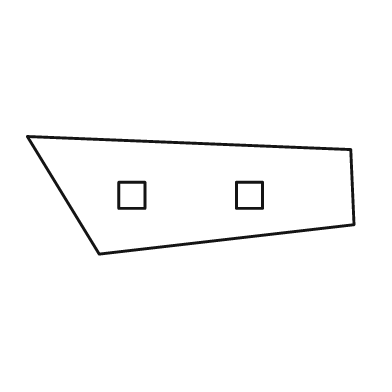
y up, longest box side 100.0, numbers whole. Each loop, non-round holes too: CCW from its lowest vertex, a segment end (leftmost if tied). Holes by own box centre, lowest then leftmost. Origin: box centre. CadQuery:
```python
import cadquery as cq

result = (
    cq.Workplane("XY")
    .moveTo(-28.0, -18.0)
    .lineTo(50.0, -9.0)
    .lineTo(49.0, 14.0)
    .lineTo(-50.0, 18.0)
    .close()
    .moveTo(-22.0, -4.0)
    .lineTo(-14.0, -4.0)
    .lineTo(-14.0, 4.0)
    .lineTo(-22.0, 4.0)
    .close()
    .moveTo(14.0, -4.0)
    .lineTo(22.0, -4.0)
    .lineTo(22.0, 4.0)
    .lineTo(14.0, 4.0)
    .close()
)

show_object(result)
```